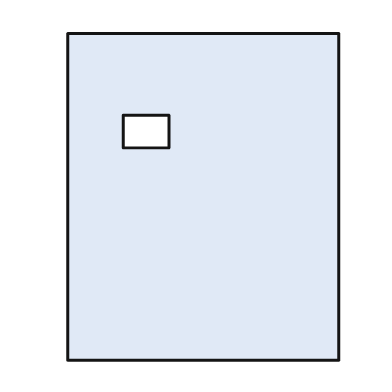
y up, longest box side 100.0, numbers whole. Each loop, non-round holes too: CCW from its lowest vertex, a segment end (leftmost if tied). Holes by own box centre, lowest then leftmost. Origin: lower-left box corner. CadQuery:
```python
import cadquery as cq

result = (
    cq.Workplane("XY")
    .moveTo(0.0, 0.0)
    .lineTo(83.0, 0.0)
    .lineTo(83.0, 100.0)
    .lineTo(0.0, 100.0)
    .close()
    .moveTo(17.0, 65.0)
    .lineTo(31.0, 65.0)
    .lineTo(31.0, 75.0)
    .lineTo(17.0, 75.0)
    .close()
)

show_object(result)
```